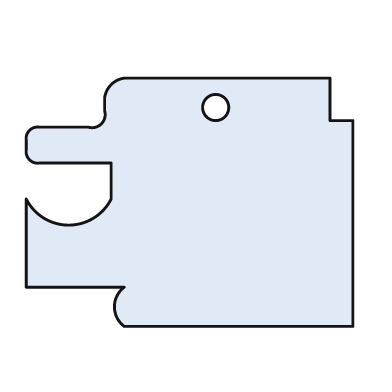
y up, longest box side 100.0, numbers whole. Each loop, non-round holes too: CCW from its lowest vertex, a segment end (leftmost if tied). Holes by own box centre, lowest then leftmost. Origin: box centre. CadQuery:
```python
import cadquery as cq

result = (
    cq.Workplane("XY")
    .moveTo(-20.0, -38.0)
    .lineTo(50.0, -38.0)
    .lineTo(50.0, 25.0)
    .lineTo(43.0, 25.0)
    .lineTo(43.0, 38.0)
    .lineTo(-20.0, 38.0)
    .threePointArc((-24.0, 36.0), (-26.0, 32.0))
    .lineTo(-26.0, 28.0)
    .threePointArc((-27.0, 24.0), (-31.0, 23.0))
    .lineTo(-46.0, 23.0)
    .threePointArc((-49.0, 22.0), (-50.0, 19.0))
    .lineTo(-50.0, 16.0)
    .threePointArc((-49.0, 13.0), (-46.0, 12.0))
    .lineTo(-24.0, 12.0)
    .lineTo(-24.0, 1.0)
    .threePointArc((-37.0, -7.0), (-50.0, 1.0))
    .lineTo(-50.0, -26.0)
    .lineTo(-20.0, -26.0)
    .threePointArc((-23.0, -32.0), (-20.0, -38.0))
    .close()
    .moveTo(8.0, 29.0)
    .circle(4.0)
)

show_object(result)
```